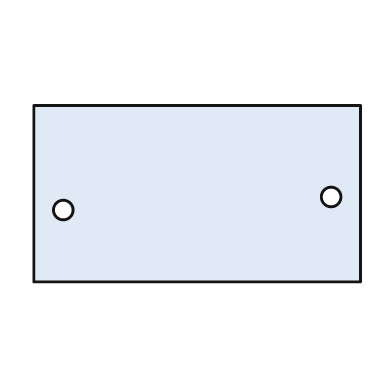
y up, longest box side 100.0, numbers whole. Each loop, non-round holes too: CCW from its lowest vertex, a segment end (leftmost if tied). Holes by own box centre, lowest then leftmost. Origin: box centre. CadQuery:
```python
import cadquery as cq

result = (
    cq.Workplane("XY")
    .moveTo(-50.0, -27.0)
    .lineTo(50.0, -27.0)
    .lineTo(50.0, 27.0)
    .lineTo(-50.0, 27.0)
    .close()
    .moveTo(-41.0, -5.0)
    .circle(3.0)
    .moveTo(41.0, -1.0)
    .circle(3.0)
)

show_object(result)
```